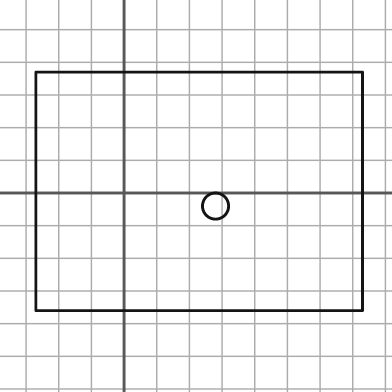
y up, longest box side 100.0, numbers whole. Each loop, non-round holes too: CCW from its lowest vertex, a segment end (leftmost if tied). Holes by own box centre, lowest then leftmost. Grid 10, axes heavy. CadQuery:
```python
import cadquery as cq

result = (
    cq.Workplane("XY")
    .moveTo(-27.0, -36.0)
    .lineTo(73.0, -36.0)
    .lineTo(73.0, 37.0)
    .lineTo(-27.0, 37.0)
    .close()
    .moveTo(28.0, -4.0)
    .circle(4.0)
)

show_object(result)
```